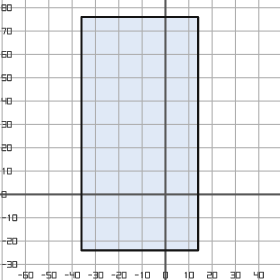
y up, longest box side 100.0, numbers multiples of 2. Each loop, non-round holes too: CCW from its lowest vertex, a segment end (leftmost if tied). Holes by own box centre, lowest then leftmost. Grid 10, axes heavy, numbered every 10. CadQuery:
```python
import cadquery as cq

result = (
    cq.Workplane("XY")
    .moveTo(-36.0, -24.0)
    .lineTo(14.0, -24.0)
    .lineTo(14.0, 76.0)
    .lineTo(-36.0, 76.0)
    .close()
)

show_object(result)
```